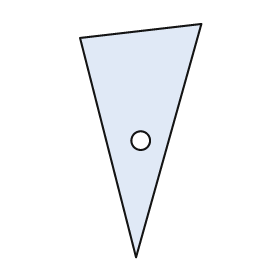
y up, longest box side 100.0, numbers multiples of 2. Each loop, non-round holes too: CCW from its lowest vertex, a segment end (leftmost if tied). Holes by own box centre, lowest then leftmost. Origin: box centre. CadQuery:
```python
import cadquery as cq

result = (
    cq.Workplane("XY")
    .moveTo(-2.0, -50.0)
    .lineTo(26.0, 50.0)
    .lineTo(-26.0, 44.0)
    .close()
    .moveTo(0.0, 0.0)
    .circle(4.0)
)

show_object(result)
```